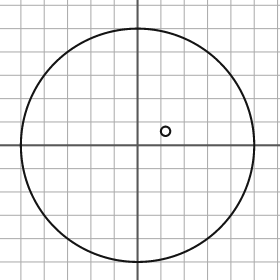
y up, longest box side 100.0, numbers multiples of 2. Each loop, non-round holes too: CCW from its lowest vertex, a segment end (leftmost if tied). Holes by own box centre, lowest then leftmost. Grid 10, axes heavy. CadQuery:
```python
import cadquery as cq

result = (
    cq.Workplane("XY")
    .moveTo(0.0, 0.0)
    .circle(50.0)
    .moveTo(12.0, 6.0)
    .circle(2.0)
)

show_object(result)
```